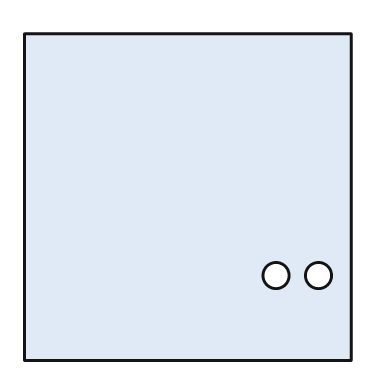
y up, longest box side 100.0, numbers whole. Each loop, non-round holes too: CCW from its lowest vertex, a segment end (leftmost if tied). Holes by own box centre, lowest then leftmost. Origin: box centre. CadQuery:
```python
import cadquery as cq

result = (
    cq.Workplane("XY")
    .moveTo(-50.0, -50.0)
    .lineTo(50.0, -50.0)
    .lineTo(50.0, 50.0)
    .lineTo(-50.0, 50.0)
    .close()
    .moveTo(27.0, -24.0)
    .circle(4.0)
    .moveTo(40.0, -24.0)
    .circle(4.0)
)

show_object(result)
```